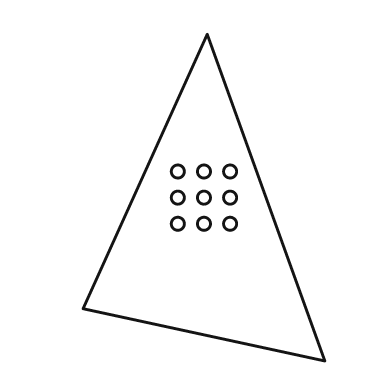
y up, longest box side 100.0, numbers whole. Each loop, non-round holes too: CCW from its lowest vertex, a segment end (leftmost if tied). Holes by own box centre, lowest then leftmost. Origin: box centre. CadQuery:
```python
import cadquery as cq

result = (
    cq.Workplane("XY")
    .moveTo(37.0, -50.0)
    .lineTo(1.0, 50.0)
    .lineTo(-37.0, -34.0)
    .close()
    .moveTo(-8.0, -8.0)
    .circle(2.0)
    .moveTo(0.0, -8.0)
    .circle(2.0)
    .moveTo(8.0, -8.0)
    .circle(2.0)
    .moveTo(-8.0, 0.0)
    .circle(2.0)
    .moveTo(0.0, 0.0)
    .circle(2.0)
    .moveTo(8.0, 0.0)
    .circle(2.0)
    .moveTo(-8.0, 8.0)
    .circle(2.0)
    .moveTo(0.0, 8.0)
    .circle(2.0)
    .moveTo(8.0, 8.0)
    .circle(2.0)
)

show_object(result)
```